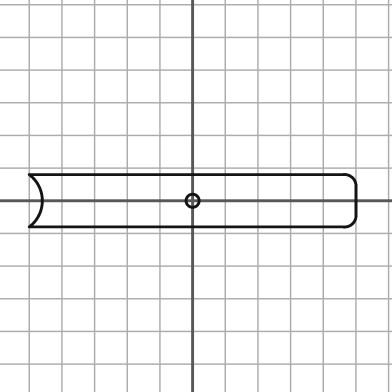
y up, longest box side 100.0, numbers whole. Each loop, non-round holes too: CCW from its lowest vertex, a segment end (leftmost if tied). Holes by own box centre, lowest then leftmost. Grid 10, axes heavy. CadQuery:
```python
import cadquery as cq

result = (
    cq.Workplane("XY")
    .moveTo(-50.0, -8.0)
    .lineTo(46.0, -8.0)
    .threePointArc((49.0, -7.0), (50.0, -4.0))
    .lineTo(50.0, 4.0)
    .threePointArc((49.0, 7.0), (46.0, 8.0))
    .lineTo(-50.0, 8.0)
    .threePointArc((-46.0, 0.0), (-50.0, -8.0))
    .close()
    .moveTo(0.0, 0.0)
    .circle(2.0)
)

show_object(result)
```